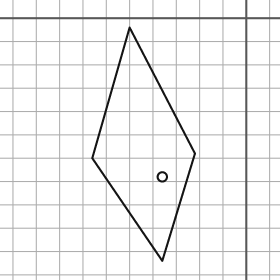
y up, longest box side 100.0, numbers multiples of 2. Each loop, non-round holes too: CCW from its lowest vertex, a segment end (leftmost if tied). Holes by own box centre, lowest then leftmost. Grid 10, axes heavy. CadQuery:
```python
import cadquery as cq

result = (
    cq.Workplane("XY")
    .moveTo(-36.0, -104.0)
    .lineTo(-22.0, -58.0)
    .lineTo(-50.0, -4.0)
    .lineTo(-66.0, -60.0)
    .close()
    .moveTo(-36.0, -68.0)
    .circle(2.0)
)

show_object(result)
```